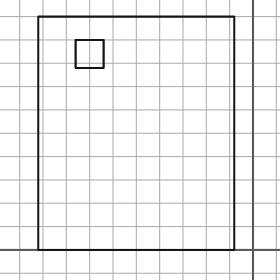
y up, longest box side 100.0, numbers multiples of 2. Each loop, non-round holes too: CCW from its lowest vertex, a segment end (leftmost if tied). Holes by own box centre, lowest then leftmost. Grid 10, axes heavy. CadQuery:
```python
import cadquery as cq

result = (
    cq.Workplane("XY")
    .moveTo(-92.0, 0.0)
    .lineTo(-8.0, 0.0)
    .lineTo(-8.0, 100.0)
    .lineTo(-92.0, 100.0)
    .close()
    .moveTo(-76.0, 78.0)
    .lineTo(-64.0, 78.0)
    .lineTo(-64.0, 90.0)
    .lineTo(-76.0, 90.0)
    .close()
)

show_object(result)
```